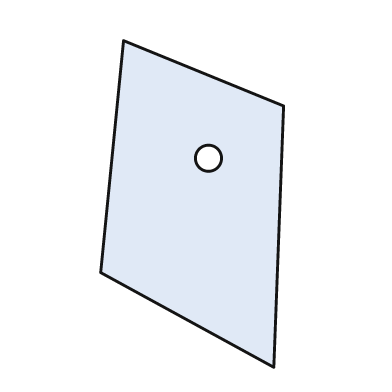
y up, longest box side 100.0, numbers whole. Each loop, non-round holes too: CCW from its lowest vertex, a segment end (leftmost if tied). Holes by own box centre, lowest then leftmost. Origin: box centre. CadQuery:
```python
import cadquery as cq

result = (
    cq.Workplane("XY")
    .moveTo(25.0, -50.0)
    .lineTo(28.0, 30.0)
    .lineTo(-21.0, 50.0)
    .lineTo(-28.0, -21.0)
    .close()
    .moveTo(5.0, 14.0)
    .circle(4.0)
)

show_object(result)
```